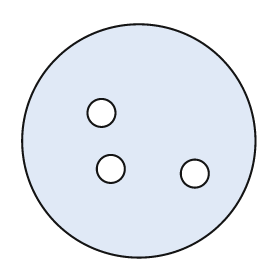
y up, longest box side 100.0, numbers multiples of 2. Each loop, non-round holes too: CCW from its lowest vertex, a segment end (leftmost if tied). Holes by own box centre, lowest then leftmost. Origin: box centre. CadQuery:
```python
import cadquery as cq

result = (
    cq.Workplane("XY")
    .moveTo(0.0, 0.0)
    .circle(50.0)
    .moveTo(24.0, -14.0)
    .circle(6.0)
    .moveTo(-12.0, -12.0)
    .circle(6.0)
    .moveTo(-16.0, 12.0)
    .circle(6.0)
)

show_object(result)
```